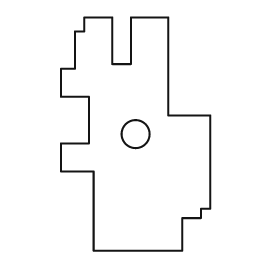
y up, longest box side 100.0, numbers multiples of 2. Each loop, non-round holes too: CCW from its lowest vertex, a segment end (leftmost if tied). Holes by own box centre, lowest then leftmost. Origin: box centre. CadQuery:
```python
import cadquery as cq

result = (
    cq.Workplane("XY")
    .moveTo(-18.0, -50.0)
    .lineTo(20.0, -50.0)
    .lineTo(20.0, -36.0)
    .lineTo(28.0, -36.0)
    .lineTo(28.0, -32.0)
    .lineTo(32.0, -32.0)
    .lineTo(32.0, 8.0)
    .lineTo(14.0, 8.0)
    .lineTo(14.0, 50.0)
    .lineTo(-2.0, 50.0)
    .lineTo(-2.0, 30.0)
    .lineTo(-10.0, 30.0)
    .lineTo(-10.0, 50.0)
    .lineTo(-22.0, 50.0)
    .lineTo(-22.0, 44.0)
    .lineTo(-26.0, 44.0)
    .lineTo(-26.0, 28.0)
    .lineTo(-32.0, 28.0)
    .lineTo(-32.0, 16.0)
    .lineTo(-20.0, 16.0)
    .lineTo(-20.0, -4.0)
    .lineTo(-32.0, -4.0)
    .lineTo(-32.0, -16.0)
    .lineTo(-18.0, -16.0)
    .close()
    .moveTo(0.0, 0.0)
    .circle(6.0)
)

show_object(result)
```